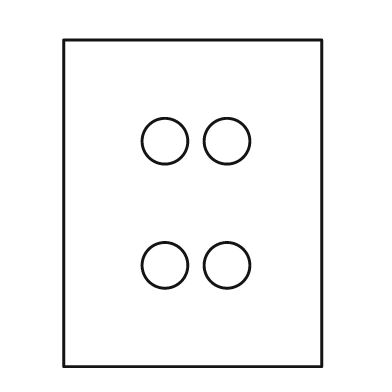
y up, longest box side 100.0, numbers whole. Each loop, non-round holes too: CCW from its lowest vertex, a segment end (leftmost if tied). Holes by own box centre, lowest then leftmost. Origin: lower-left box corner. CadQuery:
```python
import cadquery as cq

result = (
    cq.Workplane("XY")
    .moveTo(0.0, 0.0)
    .lineTo(79.0, 0.0)
    .lineTo(79.0, 100.0)
    .lineTo(0.0, 100.0)
    .close()
    .moveTo(31.0, 31.0)
    .circle(7.0)
    .moveTo(50.0, 31.0)
    .circle(7.0)
    .moveTo(31.0, 69.0)
    .circle(7.0)
    .moveTo(50.0, 69.0)
    .circle(7.0)
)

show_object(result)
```